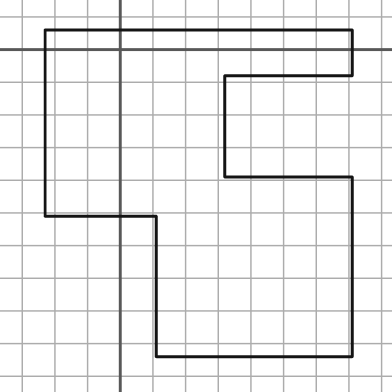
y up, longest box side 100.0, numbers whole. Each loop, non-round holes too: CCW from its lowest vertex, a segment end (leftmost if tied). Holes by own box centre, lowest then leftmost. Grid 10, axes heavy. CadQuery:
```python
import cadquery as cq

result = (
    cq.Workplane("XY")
    .moveTo(11.0, -94.0)
    .lineTo(71.0, -94.0)
    .lineTo(71.0, -39.0)
    .lineTo(32.0, -39.0)
    .lineTo(32.0, -8.0)
    .lineTo(71.0, -8.0)
    .lineTo(71.0, 6.0)
    .lineTo(-23.0, 6.0)
    .lineTo(-23.0, -51.0)
    .lineTo(11.0, -51.0)
    .close()
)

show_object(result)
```